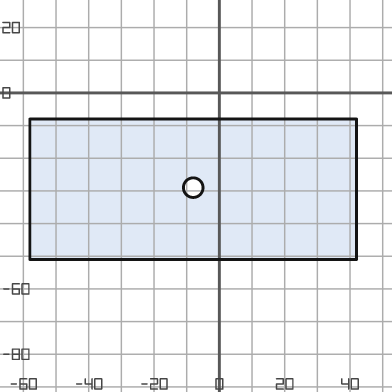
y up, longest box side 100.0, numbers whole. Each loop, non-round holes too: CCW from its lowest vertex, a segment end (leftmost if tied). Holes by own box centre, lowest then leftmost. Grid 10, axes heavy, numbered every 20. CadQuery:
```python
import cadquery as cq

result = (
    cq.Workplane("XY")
    .moveTo(-58.0, -51.0)
    .lineTo(42.0, -51.0)
    .lineTo(42.0, -8.0)
    .lineTo(-58.0, -8.0)
    .close()
    .moveTo(-8.0, -29.0)
    .circle(3.0)
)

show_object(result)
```